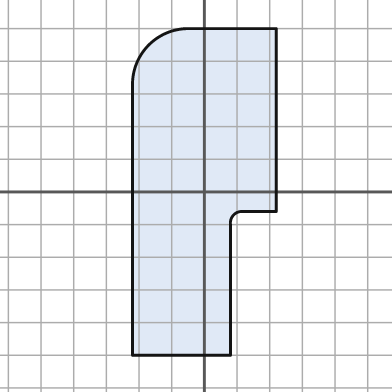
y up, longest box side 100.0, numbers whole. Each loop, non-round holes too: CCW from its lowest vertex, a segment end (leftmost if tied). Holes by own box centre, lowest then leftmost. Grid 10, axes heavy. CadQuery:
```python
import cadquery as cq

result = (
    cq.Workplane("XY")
    .moveTo(-22.0, -50.0)
    .lineTo(8.0, -50.0)
    .lineTo(8.0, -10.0)
    .threePointArc((9.0, -7.0), (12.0, -6.0))
    .lineTo(22.0, -6.0)
    .lineTo(22.0, 50.0)
    .lineTo(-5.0, 50.0)
    .threePointArc((-17.0, 45.0), (-22.0, 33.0))
    .close()
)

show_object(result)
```